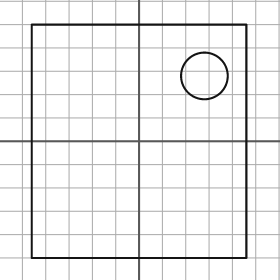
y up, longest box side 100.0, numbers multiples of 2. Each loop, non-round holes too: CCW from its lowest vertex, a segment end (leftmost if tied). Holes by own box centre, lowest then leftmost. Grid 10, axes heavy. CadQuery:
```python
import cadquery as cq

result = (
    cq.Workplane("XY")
    .moveTo(-46.0, -50.0)
    .lineTo(46.0, -50.0)
    .lineTo(46.0, 50.0)
    .lineTo(-46.0, 50.0)
    .close()
    .moveTo(28.0, 28.0)
    .circle(10.0)
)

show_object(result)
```